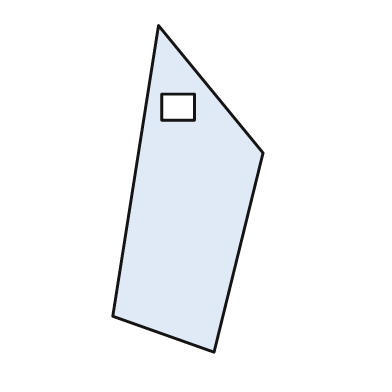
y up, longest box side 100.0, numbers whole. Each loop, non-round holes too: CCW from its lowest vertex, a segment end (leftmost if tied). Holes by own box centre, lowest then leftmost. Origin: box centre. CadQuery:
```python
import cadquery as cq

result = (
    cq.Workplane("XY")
    .moveTo(8.0, -50.0)
    .lineTo(23.0, 11.0)
    .lineTo(-9.0, 50.0)
    .lineTo(-23.0, -39.0)
    .close()
    .moveTo(-8.0, 21.0)
    .lineTo(2.0, 21.0)
    .lineTo(2.0, 29.0)
    .lineTo(-8.0, 29.0)
    .close()
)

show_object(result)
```